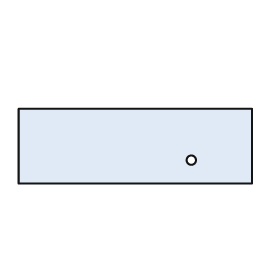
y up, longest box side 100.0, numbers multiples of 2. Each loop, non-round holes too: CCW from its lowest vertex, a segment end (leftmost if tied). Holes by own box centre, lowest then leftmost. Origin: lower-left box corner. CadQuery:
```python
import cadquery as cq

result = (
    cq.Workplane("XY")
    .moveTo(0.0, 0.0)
    .lineTo(100.0, 0.0)
    .lineTo(100.0, 32.0)
    .lineTo(0.0, 32.0)
    .close()
    .moveTo(74.0, 10.0)
    .circle(2.0)
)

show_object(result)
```